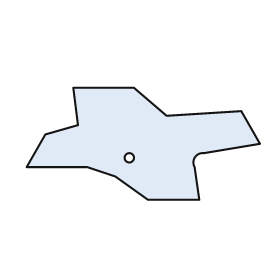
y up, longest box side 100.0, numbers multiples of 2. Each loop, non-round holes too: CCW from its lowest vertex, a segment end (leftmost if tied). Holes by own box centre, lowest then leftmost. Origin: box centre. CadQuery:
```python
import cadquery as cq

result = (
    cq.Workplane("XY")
    .moveTo(2.0, -24.0)
    .lineTo(24.0, -24.0)
    .lineTo(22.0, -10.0)
    .threePointArc((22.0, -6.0), (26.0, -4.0))
    .lineTo(50.0, 0.0)
    .lineTo(42.0, 14.0)
    .lineTo(10.0, 12.0)
    .lineTo(-4.0, 24.0)
    .lineTo(-30.0, 24.0)
    .lineTo(-28.0, 8.0)
    .lineTo(-42.0, 4.0)
    .lineTo(-50.0, -10.0)
    .lineTo(-24.0, -10.0)
    .lineTo(-12.0, -14.0)
    .close()
    .moveTo(-6.0, -6.0)
    .circle(2.0)
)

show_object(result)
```